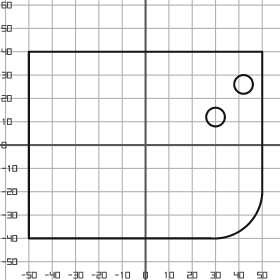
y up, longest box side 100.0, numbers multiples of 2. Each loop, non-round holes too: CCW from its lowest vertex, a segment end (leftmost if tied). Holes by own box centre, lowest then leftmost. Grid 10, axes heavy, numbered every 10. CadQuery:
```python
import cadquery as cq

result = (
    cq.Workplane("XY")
    .moveTo(-50.0, -40.0)
    .lineTo(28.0, -40.0)
    .threePointArc((44.0, -34.0), (50.0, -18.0))
    .lineTo(50.0, 40.0)
    .lineTo(-50.0, 40.0)
    .close()
    .moveTo(30.0, 12.0)
    .circle(4.0)
    .moveTo(42.0, 26.0)
    .circle(4.0)
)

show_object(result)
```